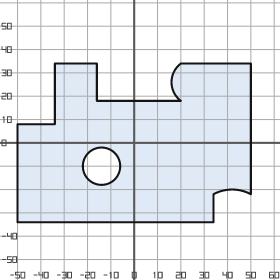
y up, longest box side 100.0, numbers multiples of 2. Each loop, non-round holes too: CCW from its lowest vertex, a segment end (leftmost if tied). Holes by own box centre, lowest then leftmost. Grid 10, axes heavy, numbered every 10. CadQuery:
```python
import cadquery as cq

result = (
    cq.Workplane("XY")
    .moveTo(-50.0, -34.0)
    .lineTo(34.0, -34.0)
    .lineTo(34.0, -22.0)
    .threePointArc((42.0, -20.0), (50.0, -22.0))
    .lineTo(50.0, 34.0)
    .lineTo(20.0, 34.0)
    .threePointArc((16.0, 26.0), (20.0, 18.0))
    .lineTo(-16.0, 18.0)
    .lineTo(-16.0, 34.0)
    .lineTo(-34.0, 34.0)
    .lineTo(-34.0, 8.0)
    .lineTo(-50.0, 8.0)
    .close()
    .moveTo(-14.0, -10.0)
    .circle(8.0)
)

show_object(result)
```